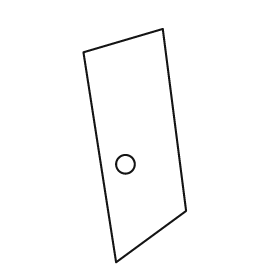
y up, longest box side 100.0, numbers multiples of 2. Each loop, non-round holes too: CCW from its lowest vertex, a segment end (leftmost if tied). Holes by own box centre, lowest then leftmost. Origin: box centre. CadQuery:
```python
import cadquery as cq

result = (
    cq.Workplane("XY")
    .moveTo(-8.0, -50.0)
    .lineTo(22.0, -28.0)
    .lineTo(12.0, 50.0)
    .lineTo(-22.0, 40.0)
    .close()
    .moveTo(-4.0, -8.0)
    .circle(4.0)
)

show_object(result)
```